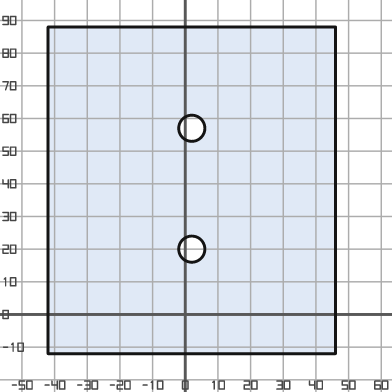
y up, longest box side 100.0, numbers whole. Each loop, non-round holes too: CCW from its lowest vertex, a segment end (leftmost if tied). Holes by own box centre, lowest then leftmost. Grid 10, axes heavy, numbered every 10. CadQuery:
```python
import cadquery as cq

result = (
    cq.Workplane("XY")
    .moveTo(-42.0, -12.0)
    .lineTo(46.0, -12.0)
    .lineTo(46.0, 88.0)
    .lineTo(-42.0, 88.0)
    .close()
    .moveTo(2.0, 20.0)
    .circle(4.0)
    .moveTo(2.0, 57.0)
    .circle(4.0)
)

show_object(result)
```